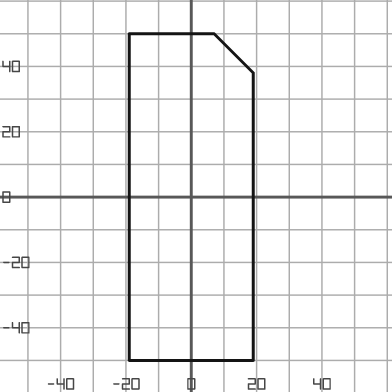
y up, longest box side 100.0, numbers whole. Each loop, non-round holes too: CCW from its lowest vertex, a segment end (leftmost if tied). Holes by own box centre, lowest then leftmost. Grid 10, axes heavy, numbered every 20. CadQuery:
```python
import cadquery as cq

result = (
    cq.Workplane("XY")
    .moveTo(-19.0, -50.0)
    .lineTo(19.0, -50.0)
    .lineTo(19.0, 38.0)
    .lineTo(7.0, 50.0)
    .lineTo(-19.0, 50.0)
    .close()
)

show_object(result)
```